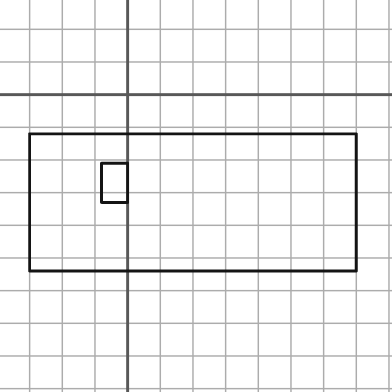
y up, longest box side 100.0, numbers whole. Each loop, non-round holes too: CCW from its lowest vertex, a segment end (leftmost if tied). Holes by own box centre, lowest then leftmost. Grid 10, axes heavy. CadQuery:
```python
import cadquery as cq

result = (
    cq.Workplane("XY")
    .moveTo(-30.0, -54.0)
    .lineTo(70.0, -54.0)
    .lineTo(70.0, -12.0)
    .lineTo(-30.0, -12.0)
    .close()
    .moveTo(-8.0, -33.0)
    .lineTo(0.0, -33.0)
    .lineTo(0.0, -21.0)
    .lineTo(-8.0, -21.0)
    .close()
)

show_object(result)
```